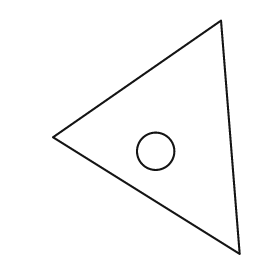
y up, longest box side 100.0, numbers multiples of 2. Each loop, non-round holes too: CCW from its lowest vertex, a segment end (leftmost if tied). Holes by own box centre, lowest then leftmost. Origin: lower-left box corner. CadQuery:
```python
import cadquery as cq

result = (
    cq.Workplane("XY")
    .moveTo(80.0, 0.0)
    .lineTo(72.0, 100.0)
    .lineTo(0.0, 50.0)
    .close()
    .moveTo(44.0, 44.0)
    .circle(8.0)
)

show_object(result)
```